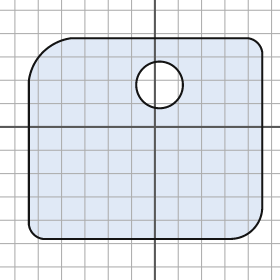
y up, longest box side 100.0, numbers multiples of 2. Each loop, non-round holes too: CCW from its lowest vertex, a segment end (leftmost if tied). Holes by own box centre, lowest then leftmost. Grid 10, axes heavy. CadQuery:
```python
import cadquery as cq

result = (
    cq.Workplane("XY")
    .moveTo(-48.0, -48.0)
    .lineTo(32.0, -48.0)
    .threePointArc((42.0, -44.0), (46.0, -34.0))
    .lineTo(46.0, 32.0)
    .threePointArc((44.0, 36.0), (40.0, 38.0))
    .lineTo(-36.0, 38.0)
    .threePointArc((-48.0, 32.0), (-54.0, 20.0))
    .lineTo(-54.0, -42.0)
    .threePointArc((-52.0, -46.0), (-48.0, -48.0))
    .close()
    .moveTo(2.0, 18.0)
    .circle(10.0)
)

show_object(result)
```